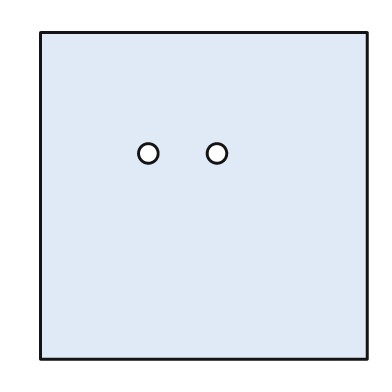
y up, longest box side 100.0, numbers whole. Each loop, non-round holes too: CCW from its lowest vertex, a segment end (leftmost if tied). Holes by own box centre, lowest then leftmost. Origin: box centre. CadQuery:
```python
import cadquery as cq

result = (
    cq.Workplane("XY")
    .moveTo(-50.0, -50.0)
    .lineTo(50.0, -50.0)
    .lineTo(50.0, 50.0)
    .lineTo(-50.0, 50.0)
    .close()
    .moveTo(-17.0, 13.0)
    .circle(3.0)
    .moveTo(4.0, 13.0)
    .circle(3.0)
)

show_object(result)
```